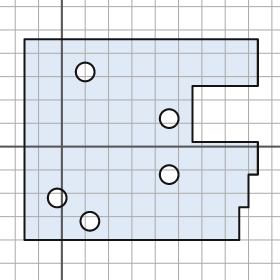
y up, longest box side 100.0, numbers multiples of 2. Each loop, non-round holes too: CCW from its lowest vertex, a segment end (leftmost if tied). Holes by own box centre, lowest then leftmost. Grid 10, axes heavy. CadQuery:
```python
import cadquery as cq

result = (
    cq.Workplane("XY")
    .moveTo(-16.0, -40.0)
    .lineTo(76.0, -40.0)
    .lineTo(76.0, -26.0)
    .lineTo(80.0, -26.0)
    .lineTo(80.0, -12.0)
    .lineTo(84.0, -12.0)
    .lineTo(84.0, 2.0)
    .lineTo(56.0, 2.0)
    .lineTo(56.0, 26.0)
    .lineTo(84.0, 26.0)
    .lineTo(84.0, 46.0)
    .lineTo(-16.0, 46.0)
    .close()
    .moveTo(12.0, -32.0)
    .circle(4.0)
    .moveTo(-2.0, -22.0)
    .circle(4.0)
    .moveTo(46.0, -12.0)
    .circle(4.0)
    .moveTo(46.0, 12.0)
    .circle(4.0)
    .moveTo(10.0, 32.0)
    .circle(4.0)
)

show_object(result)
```